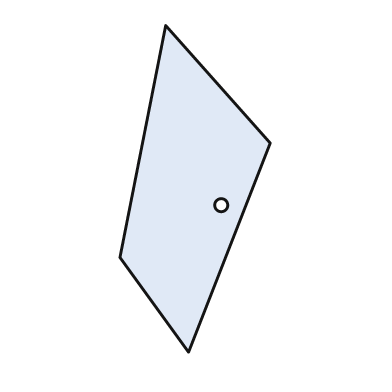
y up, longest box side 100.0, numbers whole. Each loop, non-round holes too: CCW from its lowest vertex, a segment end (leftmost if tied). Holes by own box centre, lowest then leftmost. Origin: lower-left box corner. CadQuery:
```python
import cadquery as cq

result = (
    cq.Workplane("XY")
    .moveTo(21.0, 0.0)
    .lineTo(46.0, 64.0)
    .lineTo(14.0, 100.0)
    .lineTo(0.0, 29.0)
    .close()
    .moveTo(31.0, 45.0)
    .circle(2.0)
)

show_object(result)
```